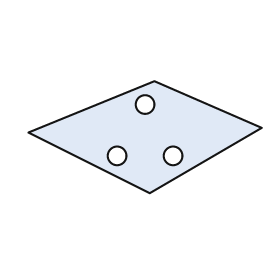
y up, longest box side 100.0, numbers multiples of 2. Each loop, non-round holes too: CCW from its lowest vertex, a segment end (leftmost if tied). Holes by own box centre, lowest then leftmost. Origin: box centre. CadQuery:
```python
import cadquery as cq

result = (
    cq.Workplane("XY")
    .moveTo(2.0, -24.0)
    .lineTo(50.0, 4.0)
    .lineTo(4.0, 24.0)
    .lineTo(-50.0, 2.0)
    .close()
    .moveTo(-12.0, -8.0)
    .circle(4.0)
    .moveTo(12.0, -8.0)
    .circle(4.0)
    .moveTo(0.0, 14.0)
    .circle(4.0)
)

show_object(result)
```